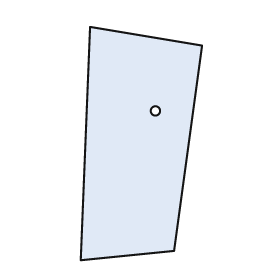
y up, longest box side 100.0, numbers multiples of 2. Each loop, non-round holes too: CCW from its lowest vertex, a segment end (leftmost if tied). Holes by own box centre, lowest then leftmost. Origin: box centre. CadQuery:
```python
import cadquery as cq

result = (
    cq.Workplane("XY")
    .moveTo(-26.0, -50.0)
    .lineTo(14.0, -46.0)
    .lineTo(26.0, 42.0)
    .lineTo(-22.0, 50.0)
    .close()
    .moveTo(6.0, 14.0)
    .circle(2.0)
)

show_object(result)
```